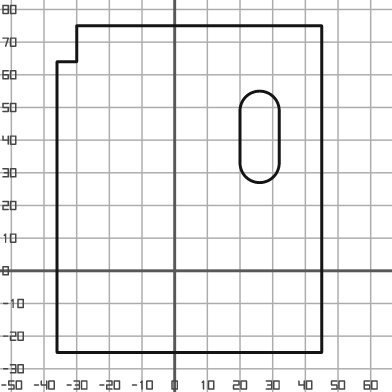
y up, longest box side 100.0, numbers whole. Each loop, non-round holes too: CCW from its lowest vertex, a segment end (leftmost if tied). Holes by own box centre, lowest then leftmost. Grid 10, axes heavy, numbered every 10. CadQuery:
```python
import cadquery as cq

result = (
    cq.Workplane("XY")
    .moveTo(-36.0, -25.0)
    .lineTo(45.0, -25.0)
    .lineTo(45.0, 75.0)
    .lineTo(-30.0, 75.0)
    .lineTo(-30.0, 64.0)
    .lineTo(-36.0, 64.0)
    .close()
    .moveTo(20.0, 33.0)
    .threePointArc((26.0, 27.0), (32.0, 33.0))
    .lineTo(32.0, 49.0)
    .threePointArc((26.0, 55.0), (20.0, 49.0))
    .close()
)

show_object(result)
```